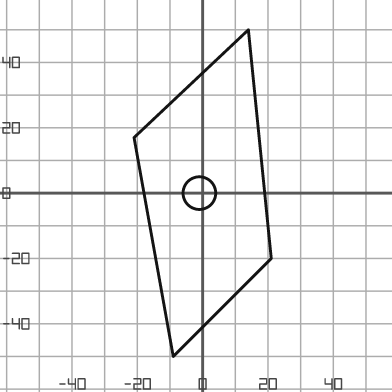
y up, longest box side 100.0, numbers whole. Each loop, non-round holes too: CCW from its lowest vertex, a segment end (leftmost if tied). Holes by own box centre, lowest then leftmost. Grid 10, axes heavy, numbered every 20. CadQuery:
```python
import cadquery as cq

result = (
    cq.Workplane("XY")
    .moveTo(-9.0, -50.0)
    .lineTo(21.0, -20.0)
    .lineTo(14.0, 50.0)
    .lineTo(-21.0, 17.0)
    .close()
    .moveTo(-1.0, 0.0)
    .circle(5.0)
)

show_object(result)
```